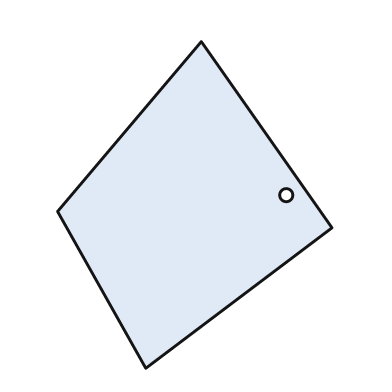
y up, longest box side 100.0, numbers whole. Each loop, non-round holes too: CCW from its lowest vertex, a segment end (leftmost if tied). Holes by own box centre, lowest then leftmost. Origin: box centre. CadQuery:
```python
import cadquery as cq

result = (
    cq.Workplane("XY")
    .moveTo(-15.0, -50.0)
    .lineTo(42.0, -7.0)
    .lineTo(2.0, 50.0)
    .lineTo(-42.0, -2.0)
    .close()
    .moveTo(28.0, 3.0)
    .circle(2.0)
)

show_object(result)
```